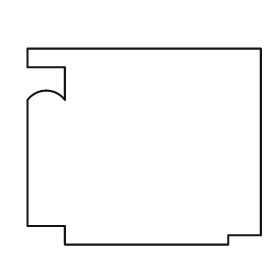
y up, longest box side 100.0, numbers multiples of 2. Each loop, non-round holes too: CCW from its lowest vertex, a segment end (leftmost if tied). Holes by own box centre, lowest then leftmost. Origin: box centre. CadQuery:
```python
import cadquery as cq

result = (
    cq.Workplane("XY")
    .moveTo(-34.0, -42.0)
    .lineTo(36.0, -42.0)
    .lineTo(36.0, -38.0)
    .lineTo(50.0, -38.0)
    .lineTo(50.0, 42.0)
    .lineTo(-50.0, 42.0)
    .lineTo(-50.0, 34.0)
    .lineTo(-34.0, 34.0)
    .lineTo(-34.0, 20.0)
    .threePointArc((-42.0, 24.0), (-50.0, 20.0))
    .lineTo(-50.0, -34.0)
    .lineTo(-34.0, -34.0)
    .close()
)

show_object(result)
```